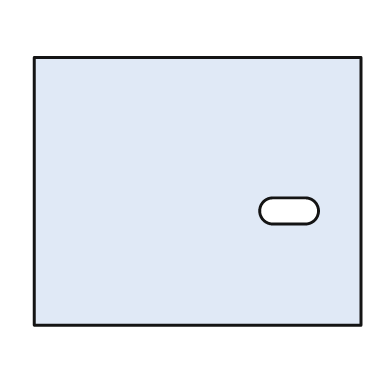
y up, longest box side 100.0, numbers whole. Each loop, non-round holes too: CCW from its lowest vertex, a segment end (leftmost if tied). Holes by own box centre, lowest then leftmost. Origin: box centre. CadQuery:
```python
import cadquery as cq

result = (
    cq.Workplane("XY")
    .moveTo(-50.0, -41.0)
    .lineTo(50.0, -41.0)
    .lineTo(50.0, 41.0)
    .lineTo(-50.0, 41.0)
    .close()
    .moveTo(23.0, -10.0)
    .lineTo(33.0, -10.0)
    .threePointArc((37.0, -6.0), (33.0, -2.0))
    .lineTo(23.0, -2.0)
    .threePointArc((19.0, -6.0), (23.0, -10.0))
    .close()
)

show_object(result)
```